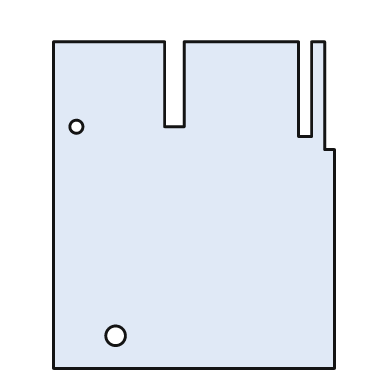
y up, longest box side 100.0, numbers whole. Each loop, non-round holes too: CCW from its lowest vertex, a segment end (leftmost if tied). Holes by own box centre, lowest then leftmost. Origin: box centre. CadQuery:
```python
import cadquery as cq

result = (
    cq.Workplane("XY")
    .moveTo(-43.0, -50.0)
    .lineTo(43.0, -50.0)
    .lineTo(43.0, 17.0)
    .lineTo(40.0, 17.0)
    .lineTo(40.0, 50.0)
    .lineTo(36.0, 50.0)
    .lineTo(36.0, 21.0)
    .lineTo(32.0, 21.0)
    .lineTo(32.0, 50.0)
    .lineTo(-3.0, 50.0)
    .lineTo(-3.0, 24.0)
    .lineTo(-9.0, 24.0)
    .lineTo(-9.0, 50.0)
    .lineTo(-43.0, 50.0)
    .close()
    .moveTo(-24.0, -40.0)
    .circle(3.0)
    .moveTo(-36.0, 24.0)
    .circle(2.0)
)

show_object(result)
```